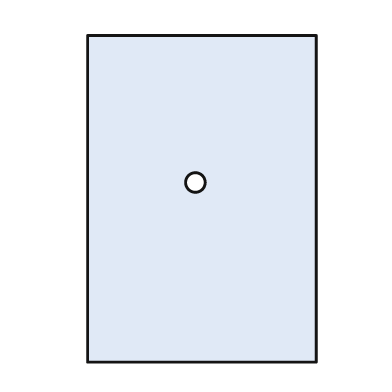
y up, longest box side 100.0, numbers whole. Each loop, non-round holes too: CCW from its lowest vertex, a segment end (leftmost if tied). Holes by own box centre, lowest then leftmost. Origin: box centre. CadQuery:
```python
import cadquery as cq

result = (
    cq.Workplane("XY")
    .moveTo(-35.0, -50.0)
    .lineTo(35.0, -50.0)
    .lineTo(35.0, 50.0)
    .lineTo(-35.0, 50.0)
    .close()
    .moveTo(-2.0, 5.0)
    .circle(3.0)
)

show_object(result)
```